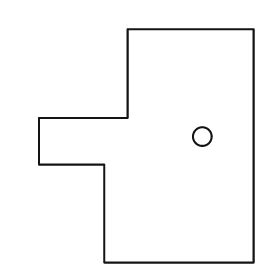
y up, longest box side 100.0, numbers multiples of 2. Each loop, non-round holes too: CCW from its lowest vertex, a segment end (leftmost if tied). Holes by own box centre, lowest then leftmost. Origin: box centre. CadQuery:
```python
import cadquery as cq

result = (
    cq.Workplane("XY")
    .moveTo(-18.0, -50.0)
    .lineTo(46.0, -50.0)
    .lineTo(46.0, 50.0)
    .lineTo(-8.0, 50.0)
    .lineTo(-8.0, 12.0)
    .lineTo(-46.0, 12.0)
    .lineTo(-46.0, -8.0)
    .lineTo(-18.0, -8.0)
    .close()
    .moveTo(24.0, 4.0)
    .circle(4.0)
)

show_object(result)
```